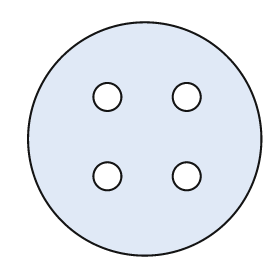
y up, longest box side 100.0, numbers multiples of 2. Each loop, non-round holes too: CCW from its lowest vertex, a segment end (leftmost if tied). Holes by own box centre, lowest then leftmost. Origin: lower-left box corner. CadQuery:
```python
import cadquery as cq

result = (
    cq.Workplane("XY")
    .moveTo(50.0, 50.0)
    .circle(50.0)
    .moveTo(34.0, 34.0)
    .circle(6.0)
    .moveTo(68.0, 34.0)
    .circle(6.0)
    .moveTo(34.0, 68.0)
    .circle(6.0)
    .moveTo(68.0, 68.0)
    .circle(6.0)
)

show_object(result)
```